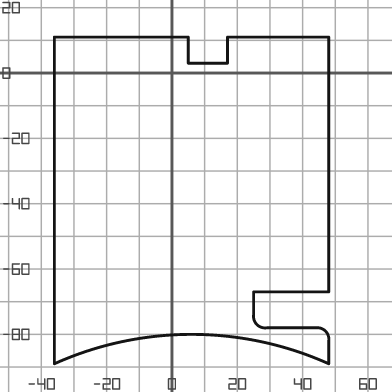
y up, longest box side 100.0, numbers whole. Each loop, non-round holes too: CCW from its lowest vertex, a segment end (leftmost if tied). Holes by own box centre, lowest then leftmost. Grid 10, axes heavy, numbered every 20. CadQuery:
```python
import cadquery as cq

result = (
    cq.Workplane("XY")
    .moveTo(-36.0, -89.0)
    .threePointArc((6.0, -80.0), (48.0, -89.0))
    .lineTo(48.0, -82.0)
    .threePointArc((47.0, -79.0), (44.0, -78.0))
    .lineTo(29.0, -78.0)
    .threePointArc((26.0, -77.0), (25.0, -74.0))
    .lineTo(25.0, -67.0)
    .lineTo(48.0, -67.0)
    .lineTo(48.0, 11.0)
    .lineTo(17.0, 11.0)
    .lineTo(17.0, 3.0)
    .lineTo(5.0, 3.0)
    .lineTo(5.0, 11.0)
    .lineTo(-36.0, 11.0)
    .close()
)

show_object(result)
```